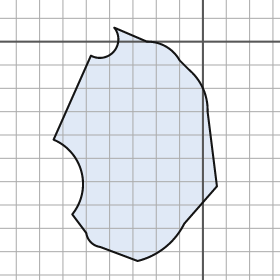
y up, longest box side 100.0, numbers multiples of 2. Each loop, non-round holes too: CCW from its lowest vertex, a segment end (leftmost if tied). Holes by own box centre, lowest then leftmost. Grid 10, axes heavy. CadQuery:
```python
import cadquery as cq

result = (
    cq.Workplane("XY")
    .moveTo(-28.0, -94.0)
    .threePointArc((-16.0, -88.0), (-8.0, -78.0))
    .lineTo(6.0, -62.0)
    .lineTo(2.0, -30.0)
    .threePointArc((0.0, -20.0), (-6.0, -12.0))
    .lineTo(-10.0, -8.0)
    .threePointArc((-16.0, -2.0), (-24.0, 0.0))
    .lineTo(-38.0, 6.0)
    .threePointArc((-38.0, -4.0), (-48.0, -6.0))
    .lineTo(-64.0, -42.0)
    .threePointArc((-52.0, -56.0), (-56.0, -74.0))
    .lineTo(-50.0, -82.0)
    .threePointArc((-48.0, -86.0), (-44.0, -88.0))
    .close()
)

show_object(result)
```